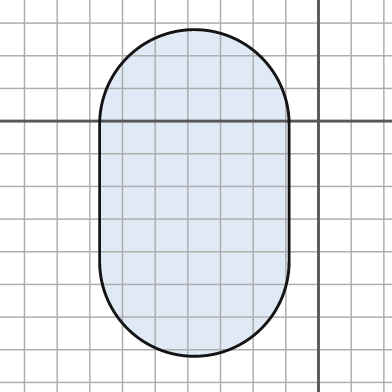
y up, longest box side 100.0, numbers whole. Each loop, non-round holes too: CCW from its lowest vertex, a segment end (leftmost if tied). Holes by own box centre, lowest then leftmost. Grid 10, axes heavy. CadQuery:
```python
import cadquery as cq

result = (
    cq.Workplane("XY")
    .moveTo(-67.0, -43.0)
    .threePointArc((-38.0, -72.0), (-9.0, -43.0))
    .lineTo(-9.0, -1.0)
    .threePointArc((-38.0, 28.0), (-67.0, -1.0))
    .close()
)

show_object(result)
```